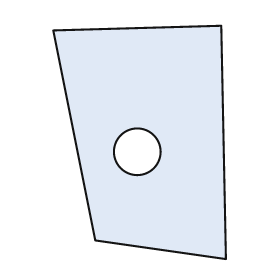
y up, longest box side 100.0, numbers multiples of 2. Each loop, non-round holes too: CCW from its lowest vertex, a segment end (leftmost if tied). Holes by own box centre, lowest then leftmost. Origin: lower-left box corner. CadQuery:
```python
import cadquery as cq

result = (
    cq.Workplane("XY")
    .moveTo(74.0, 0.0)
    .lineTo(72.0, 100.0)
    .lineTo(0.0, 98.0)
    .lineTo(18.0, 8.0)
    .close()
    .moveTo(36.0, 46.0)
    .circle(10.0)
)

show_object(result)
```